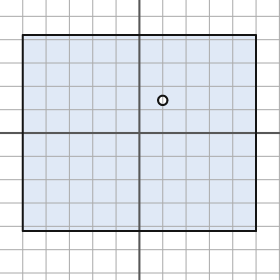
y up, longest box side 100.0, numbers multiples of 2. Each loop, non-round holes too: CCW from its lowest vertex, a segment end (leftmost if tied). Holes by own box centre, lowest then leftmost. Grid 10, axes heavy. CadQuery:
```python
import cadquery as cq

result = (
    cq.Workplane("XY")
    .moveTo(-50.0, -42.0)
    .lineTo(50.0, -42.0)
    .lineTo(50.0, 42.0)
    .lineTo(-50.0, 42.0)
    .close()
    .moveTo(10.0, 14.0)
    .circle(2.0)
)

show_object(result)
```